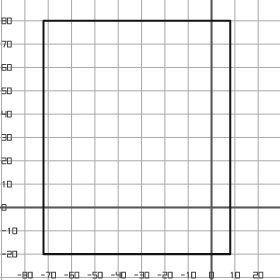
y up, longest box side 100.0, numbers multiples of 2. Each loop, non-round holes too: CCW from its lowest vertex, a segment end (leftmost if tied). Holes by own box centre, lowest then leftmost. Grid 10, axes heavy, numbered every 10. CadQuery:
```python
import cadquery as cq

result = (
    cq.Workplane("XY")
    .moveTo(-72.0, -20.0)
    .lineTo(8.0, -20.0)
    .lineTo(8.0, 80.0)
    .lineTo(-72.0, 80.0)
    .close()
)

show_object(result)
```